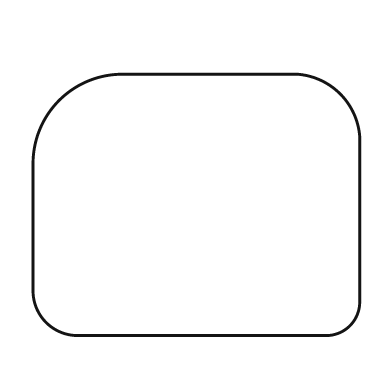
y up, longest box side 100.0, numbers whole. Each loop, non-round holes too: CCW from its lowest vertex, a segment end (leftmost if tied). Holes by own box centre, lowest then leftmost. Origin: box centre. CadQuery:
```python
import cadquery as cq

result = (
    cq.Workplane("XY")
    .moveTo(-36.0, -40.0)
    .lineTo(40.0, -40.0)
    .threePointArc((47.0, -37.0), (50.0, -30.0))
    .lineTo(50.0, 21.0)
    .threePointArc((44.0, 34.0), (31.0, 40.0))
    .lineTo(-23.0, 40.0)
    .threePointArc((-42.0, 32.0), (-50.0, 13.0))
    .lineTo(-50.0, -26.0)
    .threePointArc((-46.0, -36.0), (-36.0, -40.0))
    .close()
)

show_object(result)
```